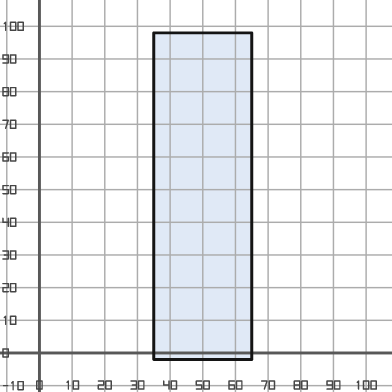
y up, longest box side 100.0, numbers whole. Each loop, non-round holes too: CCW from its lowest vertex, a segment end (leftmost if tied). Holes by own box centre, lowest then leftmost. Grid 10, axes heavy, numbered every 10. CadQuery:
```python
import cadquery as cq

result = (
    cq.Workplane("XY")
    .moveTo(35.0, -2.0)
    .lineTo(65.0, -2.0)
    .lineTo(65.0, 98.0)
    .lineTo(35.0, 98.0)
    .close()
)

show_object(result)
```